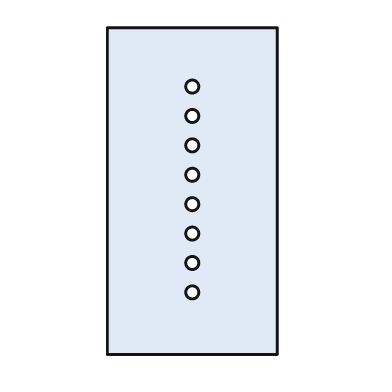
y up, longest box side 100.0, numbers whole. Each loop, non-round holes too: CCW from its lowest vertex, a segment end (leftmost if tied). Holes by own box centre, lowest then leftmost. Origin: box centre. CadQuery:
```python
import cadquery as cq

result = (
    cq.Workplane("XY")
    .moveTo(-26.0, -50.0)
    .lineTo(26.0, -50.0)
    .lineTo(26.0, 50.0)
    .lineTo(-26.0, 50.0)
    .close()
    .moveTo(0.0, -31.0)
    .circle(2.0)
    .moveTo(0.0, -22.0)
    .circle(2.0)
    .moveTo(0.0, -13.0)
    .circle(2.0)
    .moveTo(0.0, -4.0)
    .circle(2.0)
    .moveTo(0.0, 5.0)
    .circle(2.0)
    .moveTo(0.0, 14.0)
    .circle(2.0)
    .moveTo(0.0, 23.0)
    .circle(2.0)
    .moveTo(0.0, 32.0)
    .circle(2.0)
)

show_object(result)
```